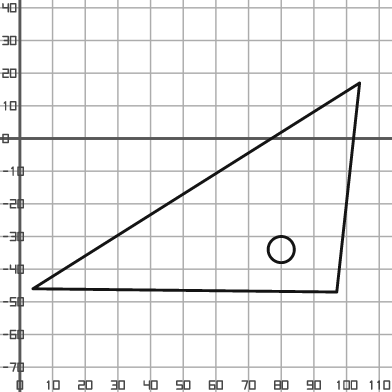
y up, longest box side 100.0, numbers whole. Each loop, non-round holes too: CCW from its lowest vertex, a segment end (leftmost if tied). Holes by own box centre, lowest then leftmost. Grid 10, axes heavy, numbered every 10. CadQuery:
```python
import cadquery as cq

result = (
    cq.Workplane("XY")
    .moveTo(97.0, -47.0)
    .lineTo(104.0, 17.0)
    .lineTo(4.0, -46.0)
    .close()
    .moveTo(80.0, -34.0)
    .circle(4.0)
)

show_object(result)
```